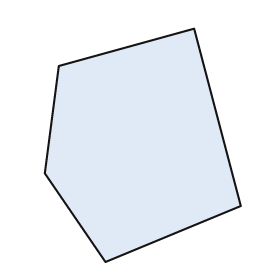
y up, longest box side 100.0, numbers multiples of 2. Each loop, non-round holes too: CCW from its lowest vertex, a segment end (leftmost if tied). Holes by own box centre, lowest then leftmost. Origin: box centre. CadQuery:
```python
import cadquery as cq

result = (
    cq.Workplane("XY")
    .moveTo(-16.0, -50.0)
    .lineTo(42.0, -26.0)
    .lineTo(22.0, 50.0)
    .lineTo(-36.0, 34.0)
    .lineTo(-42.0, -12.0)
    .close()
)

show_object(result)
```